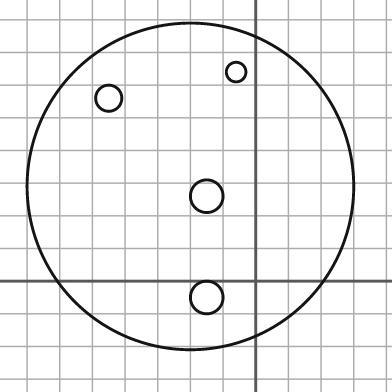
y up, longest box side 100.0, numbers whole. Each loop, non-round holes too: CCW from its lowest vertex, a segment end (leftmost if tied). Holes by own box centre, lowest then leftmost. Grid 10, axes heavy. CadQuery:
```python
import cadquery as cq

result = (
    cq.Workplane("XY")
    .moveTo(-20.0, 29.0)
    .circle(50.0)
    .moveTo(-15.0, -5.0)
    .circle(5.0)
    .moveTo(-15.0, 26.0)
    .circle(5.0)
    .moveTo(-45.0, 56.0)
    .circle(4.0)
    .moveTo(-6.0, 64.0)
    .circle(3.0)
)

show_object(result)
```